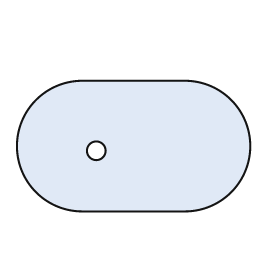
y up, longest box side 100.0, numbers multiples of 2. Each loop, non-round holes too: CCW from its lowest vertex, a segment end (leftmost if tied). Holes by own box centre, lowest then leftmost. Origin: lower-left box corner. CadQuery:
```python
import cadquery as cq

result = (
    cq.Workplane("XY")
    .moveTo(28.0, 0.0)
    .lineTo(72.0, 0.0)
    .threePointArc((100.0, 28.0), (72.0, 56.0))
    .lineTo(28.0, 56.0)
    .threePointArc((0.0, 28.0), (28.0, 0.0))
    .close()
    .moveTo(34.0, 26.0)
    .circle(4.0)
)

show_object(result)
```